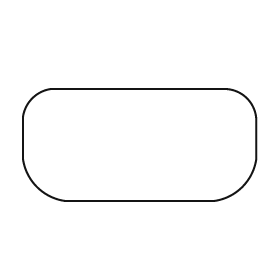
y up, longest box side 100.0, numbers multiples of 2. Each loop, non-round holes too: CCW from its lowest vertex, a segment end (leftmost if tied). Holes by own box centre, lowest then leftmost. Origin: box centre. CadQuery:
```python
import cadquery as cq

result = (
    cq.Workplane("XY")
    .moveTo(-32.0, -24.0)
    .lineTo(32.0, -24.0)
    .threePointArc((44.0, -18.0), (50.0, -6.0))
    .lineTo(50.0, 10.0)
    .threePointArc((46.0, 20.0), (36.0, 24.0))
    .lineTo(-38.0, 24.0)
    .threePointArc((-46.0, 20.0), (-50.0, 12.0))
    .lineTo(-50.0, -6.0)
    .threePointArc((-44.0, -18.0), (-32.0, -24.0))
    .close()
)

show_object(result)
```